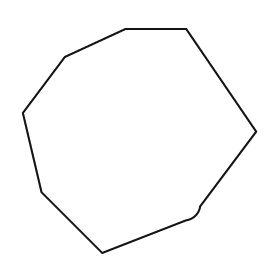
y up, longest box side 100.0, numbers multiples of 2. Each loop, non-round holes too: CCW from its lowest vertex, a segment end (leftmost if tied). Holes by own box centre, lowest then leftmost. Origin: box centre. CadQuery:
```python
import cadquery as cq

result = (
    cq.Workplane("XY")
    .moveTo(-16.0, -48.0)
    .lineTo(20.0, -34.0)
    .threePointArc((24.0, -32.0), (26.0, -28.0))
    .lineTo(50.0, 4.0)
    .lineTo(20.0, 48.0)
    .lineTo(-6.0, 48.0)
    .lineTo(-32.0, 36.0)
    .lineTo(-50.0, 12.0)
    .lineTo(-42.0, -22.0)
    .close()
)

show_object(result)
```